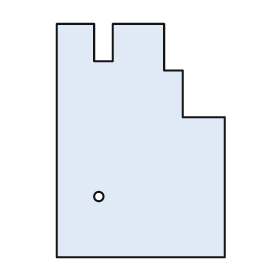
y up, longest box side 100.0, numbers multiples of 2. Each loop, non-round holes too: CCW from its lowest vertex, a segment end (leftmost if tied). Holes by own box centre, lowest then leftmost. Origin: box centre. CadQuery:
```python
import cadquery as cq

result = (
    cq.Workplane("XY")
    .moveTo(-36.0, -50.0)
    .lineTo(36.0, -50.0)
    .lineTo(36.0, 10.0)
    .lineTo(18.0, 10.0)
    .lineTo(18.0, 30.0)
    .lineTo(10.0, 30.0)
    .lineTo(10.0, 50.0)
    .lineTo(-12.0, 50.0)
    .lineTo(-12.0, 34.0)
    .lineTo(-20.0, 34.0)
    .lineTo(-20.0, 50.0)
    .lineTo(-36.0, 50.0)
    .close()
    .moveTo(-18.0, -24.0)
    .circle(2.0)
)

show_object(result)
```